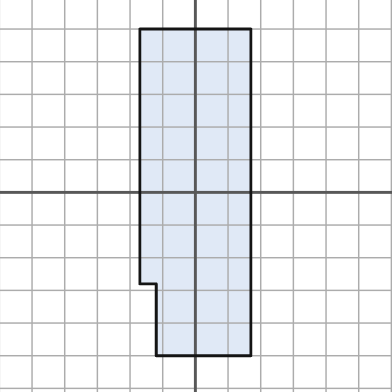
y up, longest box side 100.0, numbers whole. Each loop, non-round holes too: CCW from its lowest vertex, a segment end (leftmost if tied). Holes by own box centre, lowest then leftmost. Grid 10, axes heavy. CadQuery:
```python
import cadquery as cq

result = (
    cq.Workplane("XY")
    .moveTo(-12.0, -50.0)
    .lineTo(17.0, -50.0)
    .lineTo(17.0, 50.0)
    .lineTo(-17.0, 50.0)
    .lineTo(-17.0, -28.0)
    .lineTo(-12.0, -28.0)
    .close()
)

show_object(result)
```